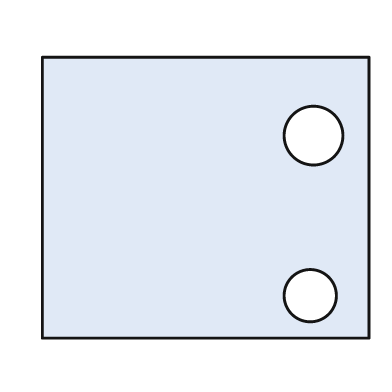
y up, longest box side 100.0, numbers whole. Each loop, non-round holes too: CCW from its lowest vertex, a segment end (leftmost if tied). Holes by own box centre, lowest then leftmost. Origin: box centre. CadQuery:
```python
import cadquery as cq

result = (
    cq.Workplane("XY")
    .moveTo(-50.0, -43.0)
    .lineTo(50.0, -43.0)
    .lineTo(50.0, 43.0)
    .lineTo(-50.0, 43.0)
    .close()
    .moveTo(32.0, -30.0)
    .circle(8.0)
    .moveTo(33.0, 19.0)
    .circle(9.0)
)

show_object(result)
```